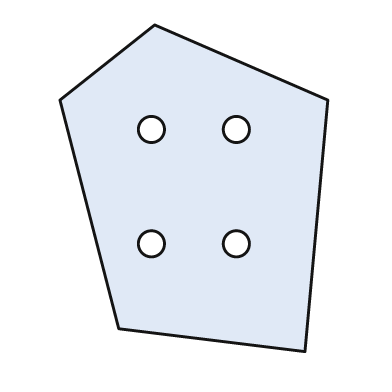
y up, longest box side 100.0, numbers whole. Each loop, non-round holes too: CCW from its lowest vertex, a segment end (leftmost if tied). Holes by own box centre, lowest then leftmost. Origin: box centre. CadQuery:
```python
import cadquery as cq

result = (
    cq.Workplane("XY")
    .moveTo(34.0, -50.0)
    .lineTo(41.0, 27.0)
    .lineTo(-12.0, 50.0)
    .lineTo(-41.0, 27.0)
    .lineTo(-23.0, -43.0)
    .close()
    .moveTo(-13.0, -17.0)
    .circle(4.0)
    .moveTo(13.0, -17.0)
    .circle(4.0)
    .moveTo(-13.0, 18.0)
    .circle(4.0)
    .moveTo(13.0, 18.0)
    .circle(4.0)
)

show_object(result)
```